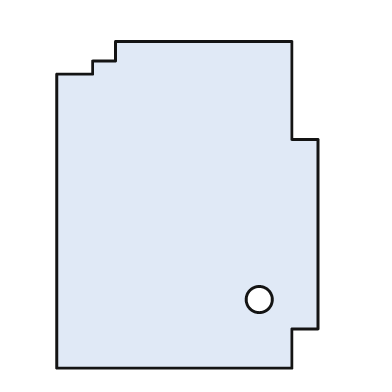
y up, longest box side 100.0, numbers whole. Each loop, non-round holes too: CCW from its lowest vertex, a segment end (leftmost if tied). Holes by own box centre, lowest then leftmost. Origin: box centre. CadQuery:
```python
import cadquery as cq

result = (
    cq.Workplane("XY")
    .moveTo(-40.0, -50.0)
    .lineTo(32.0, -50.0)
    .lineTo(32.0, -38.0)
    .lineTo(40.0, -38.0)
    .lineTo(40.0, 20.0)
    .lineTo(32.0, 20.0)
    .lineTo(32.0, 50.0)
    .lineTo(-22.0, 50.0)
    .lineTo(-22.0, 44.0)
    .lineTo(-29.0, 44.0)
    .lineTo(-29.0, 40.0)
    .lineTo(-40.0, 40.0)
    .close()
    .moveTo(22.0, -29.0)
    .circle(4.0)
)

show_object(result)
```